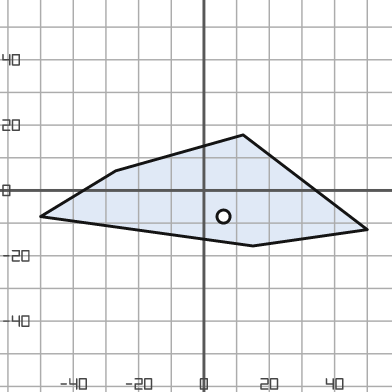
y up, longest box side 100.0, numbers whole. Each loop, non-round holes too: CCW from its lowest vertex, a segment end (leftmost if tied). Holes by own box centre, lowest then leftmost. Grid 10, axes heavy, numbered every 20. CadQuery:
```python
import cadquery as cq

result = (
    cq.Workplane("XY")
    .moveTo(15.0, -17.0)
    .lineTo(50.0, -12.0)
    .lineTo(12.0, 17.0)
    .lineTo(-27.0, 6.0)
    .lineTo(-50.0, -8.0)
    .close()
    .moveTo(6.0, -8.0)
    .circle(2.0)
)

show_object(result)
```